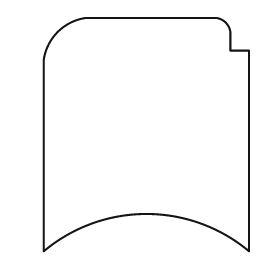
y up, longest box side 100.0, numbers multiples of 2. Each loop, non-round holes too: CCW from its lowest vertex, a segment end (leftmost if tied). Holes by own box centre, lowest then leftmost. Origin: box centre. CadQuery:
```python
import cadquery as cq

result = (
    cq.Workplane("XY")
    .moveTo(-44.0, -50.0)
    .threePointArc((0.0, -34.0), (44.0, -50.0))
    .lineTo(44.0, 36.0)
    .lineTo(36.0, 36.0)
    .lineTo(36.0, 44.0)
    .threePointArc((34.0, 48.0), (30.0, 50.0))
    .lineTo(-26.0, 50.0)
    .threePointArc((-38.0, 44.0), (-44.0, 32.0))
    .close()
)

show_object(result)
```